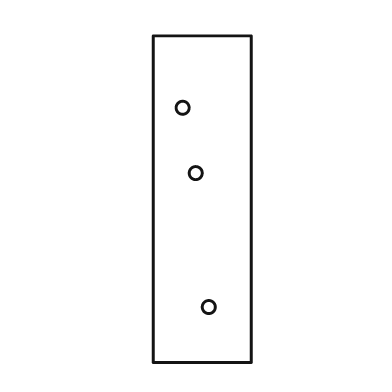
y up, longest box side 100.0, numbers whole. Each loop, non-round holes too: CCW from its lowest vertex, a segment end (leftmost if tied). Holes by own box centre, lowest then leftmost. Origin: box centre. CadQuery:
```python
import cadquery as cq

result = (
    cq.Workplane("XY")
    .moveTo(-15.0, -50.0)
    .lineTo(15.0, -50.0)
    .lineTo(15.0, 50.0)
    .lineTo(-15.0, 50.0)
    .close()
    .moveTo(2.0, -33.0)
    .circle(2.0)
    .moveTo(-2.0, 8.0)
    .circle(2.0)
    .moveTo(-6.0, 28.0)
    .circle(2.0)
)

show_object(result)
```